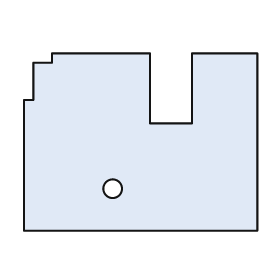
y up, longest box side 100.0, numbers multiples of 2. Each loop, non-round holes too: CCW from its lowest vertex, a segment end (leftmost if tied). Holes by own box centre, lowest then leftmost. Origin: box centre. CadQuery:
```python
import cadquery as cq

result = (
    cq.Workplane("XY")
    .moveTo(-50.0, -38.0)
    .lineTo(50.0, -38.0)
    .lineTo(50.0, 38.0)
    .lineTo(22.0, 38.0)
    .lineTo(22.0, 8.0)
    .lineTo(4.0, 8.0)
    .lineTo(4.0, 38.0)
    .lineTo(-38.0, 38.0)
    .lineTo(-38.0, 34.0)
    .lineTo(-46.0, 34.0)
    .lineTo(-46.0, 18.0)
    .lineTo(-50.0, 18.0)
    .close()
    .moveTo(-12.0, -20.0)
    .circle(4.0)
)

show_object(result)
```